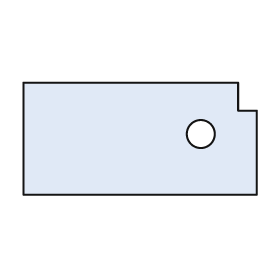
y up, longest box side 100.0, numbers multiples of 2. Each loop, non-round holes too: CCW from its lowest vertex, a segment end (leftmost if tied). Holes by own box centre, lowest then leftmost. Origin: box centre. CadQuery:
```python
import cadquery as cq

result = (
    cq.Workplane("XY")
    .moveTo(-50.0, -24.0)
    .lineTo(50.0, -24.0)
    .lineTo(50.0, 12.0)
    .lineTo(42.0, 12.0)
    .lineTo(42.0, 24.0)
    .lineTo(-50.0, 24.0)
    .close()
    .moveTo(26.0, 2.0)
    .circle(6.0)
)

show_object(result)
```